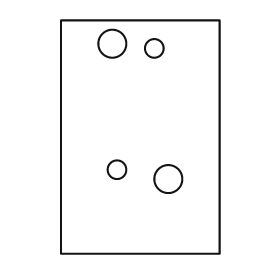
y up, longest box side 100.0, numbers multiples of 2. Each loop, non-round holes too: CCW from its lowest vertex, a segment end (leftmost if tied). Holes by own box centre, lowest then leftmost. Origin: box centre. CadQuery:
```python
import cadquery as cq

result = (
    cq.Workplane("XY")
    .moveTo(-34.0, -50.0)
    .lineTo(34.0, -50.0)
    .lineTo(34.0, 50.0)
    .lineTo(-34.0, 50.0)
    .close()
    .moveTo(12.0, -18.0)
    .circle(6.0)
    .moveTo(-10.0, -14.0)
    .circle(4.0)
    .moveTo(6.0, 38.0)
    .circle(4.0)
    .moveTo(-12.0, 40.0)
    .circle(6.0)
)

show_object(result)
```